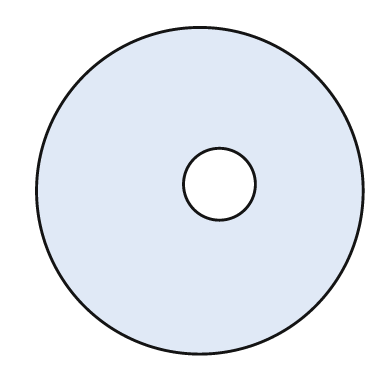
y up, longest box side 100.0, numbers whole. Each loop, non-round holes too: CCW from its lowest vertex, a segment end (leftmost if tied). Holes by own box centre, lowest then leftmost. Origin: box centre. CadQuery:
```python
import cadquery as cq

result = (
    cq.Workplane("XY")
    .moveTo(0.0, 0.0)
    .circle(50.0)
    .moveTo(6.0, 2.0)
    .circle(11.0)
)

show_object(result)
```